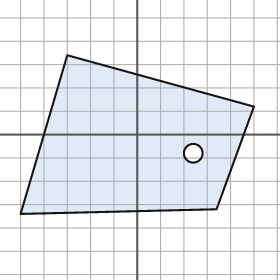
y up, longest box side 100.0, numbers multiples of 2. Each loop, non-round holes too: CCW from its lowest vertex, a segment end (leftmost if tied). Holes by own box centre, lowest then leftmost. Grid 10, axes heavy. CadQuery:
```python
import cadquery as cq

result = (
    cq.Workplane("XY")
    .moveTo(-50.0, -34.0)
    .lineTo(34.0, -32.0)
    .lineTo(50.0, 12.0)
    .lineTo(-30.0, 34.0)
    .close()
    .moveTo(24.0, -8.0)
    .circle(4.0)
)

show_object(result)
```